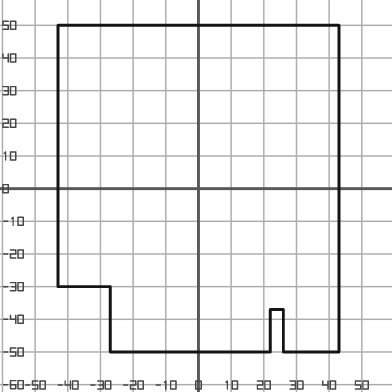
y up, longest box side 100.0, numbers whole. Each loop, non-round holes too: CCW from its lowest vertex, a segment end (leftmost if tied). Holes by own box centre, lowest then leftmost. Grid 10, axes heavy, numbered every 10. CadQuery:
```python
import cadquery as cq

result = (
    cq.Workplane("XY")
    .moveTo(-27.0, -50.0)
    .lineTo(22.0, -50.0)
    .lineTo(22.0, -37.0)
    .lineTo(26.0, -37.0)
    .lineTo(26.0, -50.0)
    .lineTo(43.0, -50.0)
    .lineTo(43.0, 50.0)
    .lineTo(-43.0, 50.0)
    .lineTo(-43.0, -30.0)
    .lineTo(-27.0, -30.0)
    .close()
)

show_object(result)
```